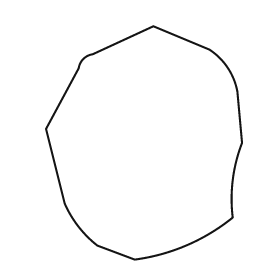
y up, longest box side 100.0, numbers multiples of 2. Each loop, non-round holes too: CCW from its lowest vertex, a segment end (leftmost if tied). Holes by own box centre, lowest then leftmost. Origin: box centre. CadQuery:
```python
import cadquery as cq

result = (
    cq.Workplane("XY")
    .moveTo(-4.0, -50.0)
    .threePointArc((18.0, -44.0), (38.0, -32.0))
    .threePointArc((38.0, -16.0), (42.0, 0.0))
    .lineTo(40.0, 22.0)
    .threePointArc((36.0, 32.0), (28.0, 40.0))
    .lineTo(4.0, 50.0)
    .lineTo(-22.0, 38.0)
    .threePointArc((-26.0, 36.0), (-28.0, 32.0))
    .lineTo(-42.0, 6.0)
    .lineTo(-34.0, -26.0)
    .threePointArc((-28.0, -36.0), (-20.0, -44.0))
    .close()
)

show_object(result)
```